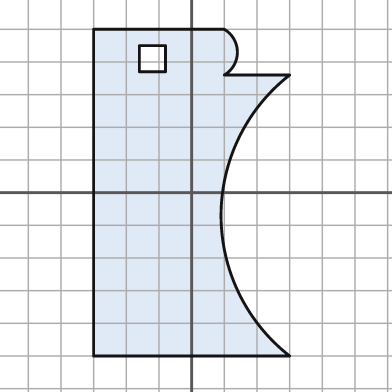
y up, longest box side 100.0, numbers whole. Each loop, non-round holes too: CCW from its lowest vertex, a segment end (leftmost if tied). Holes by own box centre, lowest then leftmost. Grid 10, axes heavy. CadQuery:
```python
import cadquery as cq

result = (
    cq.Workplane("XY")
    .moveTo(-30.0, -50.0)
    .lineTo(30.0, -50.0)
    .threePointArc((9.0, -7.0), (30.0, 36.0))
    .lineTo(10.0, 36.0)
    .threePointArc((14.0, 43.0), (10.0, 50.0))
    .lineTo(-30.0, 50.0)
    .close()
    .moveTo(-16.0, 37.0)
    .lineTo(-8.0, 37.0)
    .lineTo(-8.0, 45.0)
    .lineTo(-16.0, 45.0)
    .close()
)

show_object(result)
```